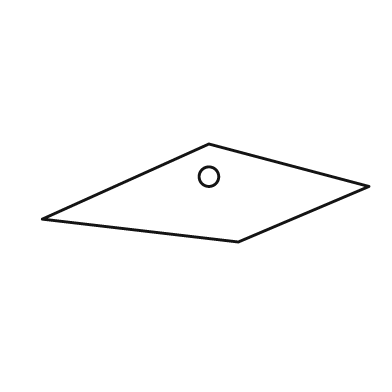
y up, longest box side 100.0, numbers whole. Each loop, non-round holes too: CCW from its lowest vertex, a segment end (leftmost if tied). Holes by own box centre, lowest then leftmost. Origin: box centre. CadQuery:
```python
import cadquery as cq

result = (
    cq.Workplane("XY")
    .moveTo(10.0, -15.0)
    .lineTo(50.0, 2.0)
    .lineTo(1.0, 15.0)
    .lineTo(-50.0, -8.0)
    .close()
    .moveTo(1.0, 5.0)
    .circle(3.0)
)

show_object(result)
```